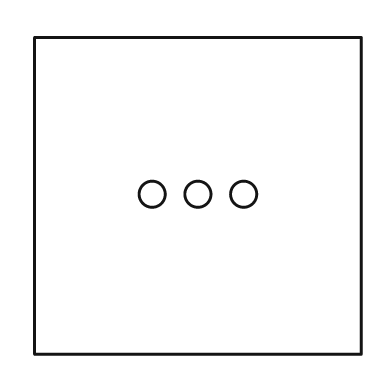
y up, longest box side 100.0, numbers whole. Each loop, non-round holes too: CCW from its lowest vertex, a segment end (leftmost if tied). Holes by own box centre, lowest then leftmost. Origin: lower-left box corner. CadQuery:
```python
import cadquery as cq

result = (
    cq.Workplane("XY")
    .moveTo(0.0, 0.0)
    .lineTo(100.0, 0.0)
    .lineTo(100.0, 97.0)
    .lineTo(0.0, 97.0)
    .close()
    .moveTo(36.0, 49.0)
    .circle(4.0)
    .moveTo(50.0, 49.0)
    .circle(4.0)
    .moveTo(64.0, 49.0)
    .circle(4.0)
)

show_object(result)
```